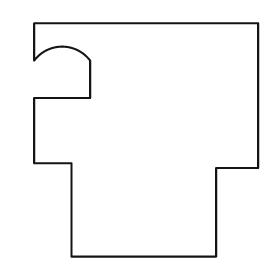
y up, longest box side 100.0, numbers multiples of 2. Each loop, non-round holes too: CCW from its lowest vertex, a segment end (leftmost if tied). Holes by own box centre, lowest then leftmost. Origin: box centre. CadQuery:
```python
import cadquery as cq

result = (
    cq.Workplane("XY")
    .moveTo(-32.0, -50.0)
    .lineTo(30.0, -50.0)
    .lineTo(30.0, -12.0)
    .lineTo(48.0, -12.0)
    .lineTo(48.0, 50.0)
    .lineTo(-48.0, 50.0)
    .lineTo(-48.0, 34.0)
    .threePointArc((-36.0, 40.0), (-24.0, 34.0))
    .lineTo(-24.0, 18.0)
    .lineTo(-48.0, 18.0)
    .lineTo(-48.0, -10.0)
    .lineTo(-32.0, -10.0)
    .close()
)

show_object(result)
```